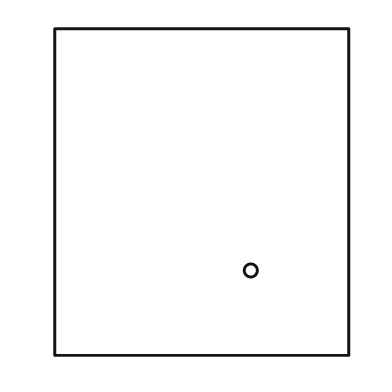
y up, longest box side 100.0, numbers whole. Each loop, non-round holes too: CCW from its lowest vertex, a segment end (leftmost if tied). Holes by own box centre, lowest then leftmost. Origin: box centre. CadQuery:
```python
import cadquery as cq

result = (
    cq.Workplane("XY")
    .moveTo(-45.0, -50.0)
    .lineTo(45.0, -50.0)
    .lineTo(45.0, 50.0)
    .lineTo(-45.0, 50.0)
    .close()
    .moveTo(15.0, -24.0)
    .circle(2.0)
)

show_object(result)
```